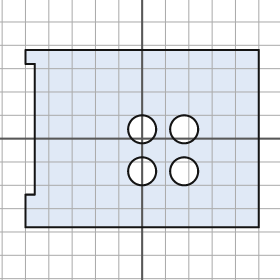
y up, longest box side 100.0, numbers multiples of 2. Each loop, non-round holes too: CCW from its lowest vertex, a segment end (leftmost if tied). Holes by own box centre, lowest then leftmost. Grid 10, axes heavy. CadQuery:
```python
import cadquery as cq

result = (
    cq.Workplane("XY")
    .moveTo(-50.0, -38.0)
    .lineTo(50.0, -38.0)
    .lineTo(50.0, 38.0)
    .lineTo(-50.0, 38.0)
    .lineTo(-50.0, 32.0)
    .lineTo(-46.0, 32.0)
    .lineTo(-46.0, -24.0)
    .lineTo(-50.0, -24.0)
    .close()
    .moveTo(0.0, -14.0)
    .circle(6.0)
    .moveTo(18.0, -14.0)
    .circle(6.0)
    .moveTo(0.0, 4.0)
    .circle(6.0)
    .moveTo(18.0, 4.0)
    .circle(6.0)
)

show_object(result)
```